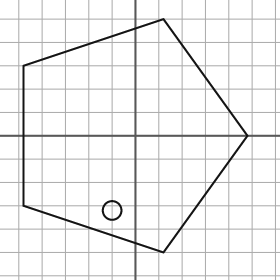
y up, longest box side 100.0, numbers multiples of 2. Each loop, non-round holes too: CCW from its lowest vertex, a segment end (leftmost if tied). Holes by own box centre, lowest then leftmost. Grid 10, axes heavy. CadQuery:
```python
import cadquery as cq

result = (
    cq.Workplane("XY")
    .moveTo(12.0, -50.0)
    .lineTo(48.0, 0.0)
    .lineTo(12.0, 50.0)
    .lineTo(-48.0, 30.0)
    .lineTo(-48.0, -30.0)
    .close()
    .moveTo(-10.0, -32.0)
    .circle(4.0)
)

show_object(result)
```